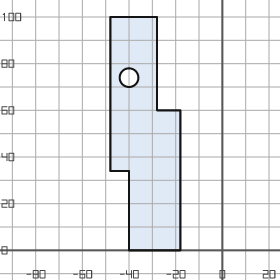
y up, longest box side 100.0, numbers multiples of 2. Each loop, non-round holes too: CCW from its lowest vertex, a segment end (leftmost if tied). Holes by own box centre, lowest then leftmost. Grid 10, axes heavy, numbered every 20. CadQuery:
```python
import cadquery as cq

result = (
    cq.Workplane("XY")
    .moveTo(-40.0, 0.0)
    .lineTo(-18.0, 0.0)
    .lineTo(-18.0, 60.0)
    .lineTo(-28.0, 60.0)
    .lineTo(-28.0, 100.0)
    .lineTo(-48.0, 100.0)
    .lineTo(-48.0, 34.0)
    .lineTo(-40.0, 34.0)
    .close()
    .moveTo(-40.0, 74.0)
    .circle(4.0)
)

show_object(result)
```